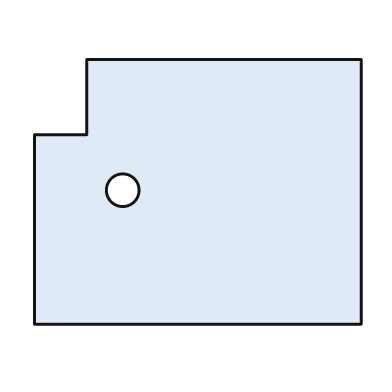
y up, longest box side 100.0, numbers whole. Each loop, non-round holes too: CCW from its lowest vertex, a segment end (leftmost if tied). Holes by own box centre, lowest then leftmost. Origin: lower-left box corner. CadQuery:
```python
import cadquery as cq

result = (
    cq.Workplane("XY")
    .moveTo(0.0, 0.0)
    .lineTo(100.0, 0.0)
    .lineTo(100.0, 81.0)
    .lineTo(16.0, 81.0)
    .lineTo(16.0, 58.0)
    .lineTo(0.0, 58.0)
    .close()
    .moveTo(27.0, 41.0)
    .circle(5.0)
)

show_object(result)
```